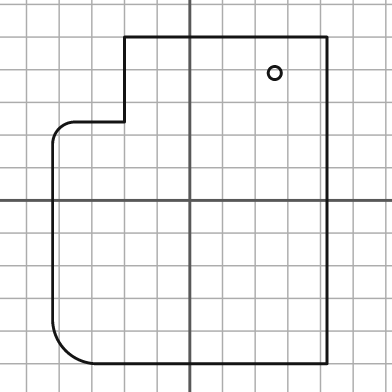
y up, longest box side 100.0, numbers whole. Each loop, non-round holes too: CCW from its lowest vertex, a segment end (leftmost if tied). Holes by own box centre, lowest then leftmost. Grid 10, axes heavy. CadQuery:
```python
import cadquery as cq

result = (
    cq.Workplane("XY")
    .moveTo(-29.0, -50.0)
    .lineTo(42.0, -50.0)
    .lineTo(42.0, 50.0)
    .lineTo(-20.0, 50.0)
    .lineTo(-20.0, 24.0)
    .lineTo(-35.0, 24.0)
    .threePointArc((-40.0, 22.0), (-42.0, 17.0))
    .lineTo(-42.0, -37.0)
    .threePointArc((-38.0, -46.0), (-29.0, -50.0))
    .close()
    .moveTo(26.0, 39.0)
    .circle(2.0)
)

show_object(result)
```